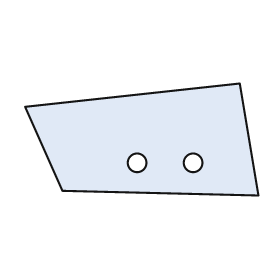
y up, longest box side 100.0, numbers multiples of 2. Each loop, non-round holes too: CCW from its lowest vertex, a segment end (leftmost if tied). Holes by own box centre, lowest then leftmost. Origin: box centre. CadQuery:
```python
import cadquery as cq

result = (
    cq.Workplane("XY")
    .moveTo(50.0, -24.0)
    .lineTo(42.0, 24.0)
    .lineTo(-50.0, 14.0)
    .lineTo(-34.0, -22.0)
    .close()
    .moveTo(-2.0, -10.0)
    .circle(4.0)
    .moveTo(22.0, -10.0)
    .circle(4.0)
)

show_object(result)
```